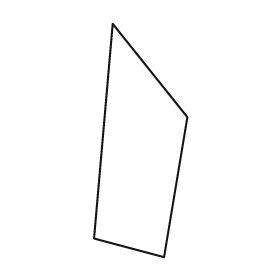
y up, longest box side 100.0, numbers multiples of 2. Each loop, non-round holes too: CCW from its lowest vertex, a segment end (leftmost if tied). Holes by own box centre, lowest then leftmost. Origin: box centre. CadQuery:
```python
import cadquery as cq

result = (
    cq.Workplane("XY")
    .moveTo(10.0, -50.0)
    .lineTo(20.0, 10.0)
    .lineTo(-12.0, 50.0)
    .lineTo(-20.0, -42.0)
    .close()
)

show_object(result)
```